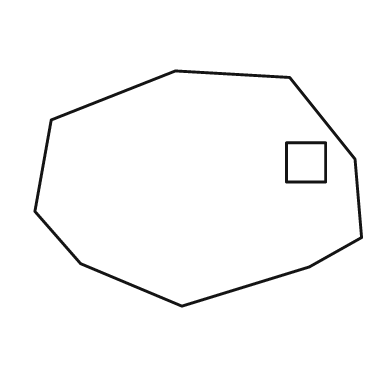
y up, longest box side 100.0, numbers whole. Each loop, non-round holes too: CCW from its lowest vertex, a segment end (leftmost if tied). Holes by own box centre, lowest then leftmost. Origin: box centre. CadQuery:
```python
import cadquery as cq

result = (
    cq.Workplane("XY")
    .moveTo(-5.0, -36.0)
    .lineTo(34.0, -24.0)
    .lineTo(50.0, -15.0)
    .lineTo(48.0, 9.0)
    .lineTo(28.0, 34.0)
    .lineTo(-7.0, 36.0)
    .lineTo(-45.0, 21.0)
    .lineTo(-50.0, -7.0)
    .lineTo(-36.0, -23.0)
    .close()
    .moveTo(27.0, 2.0)
    .lineTo(39.0, 2.0)
    .lineTo(39.0, 14.0)
    .lineTo(27.0, 14.0)
    .close()
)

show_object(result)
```